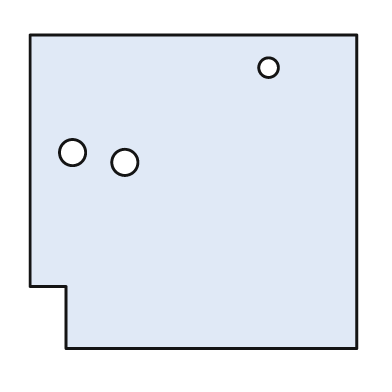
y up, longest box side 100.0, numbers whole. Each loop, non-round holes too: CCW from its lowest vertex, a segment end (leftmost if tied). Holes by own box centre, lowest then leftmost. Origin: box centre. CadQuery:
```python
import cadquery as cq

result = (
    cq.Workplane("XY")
    .moveTo(-39.0, -48.0)
    .lineTo(50.0, -48.0)
    .lineTo(50.0, 48.0)
    .lineTo(-50.0, 48.0)
    .lineTo(-50.0, -29.0)
    .lineTo(-39.0, -29.0)
    .close()
    .moveTo(-21.0, 9.0)
    .circle(4.0)
    .moveTo(-37.0, 12.0)
    .circle(4.0)
    .moveTo(23.0, 38.0)
    .circle(3.0)
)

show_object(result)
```